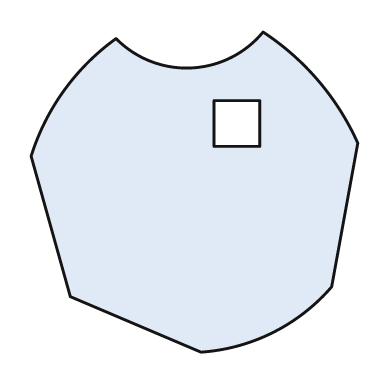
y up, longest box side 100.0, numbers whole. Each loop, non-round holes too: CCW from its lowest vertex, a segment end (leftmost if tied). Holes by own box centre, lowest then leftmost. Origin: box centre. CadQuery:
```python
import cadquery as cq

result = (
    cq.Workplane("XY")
    .moveTo(2.0, -49.0)
    .threePointArc((24.0, -43.0), (42.0, -29.0))
    .lineTo(50.0, 15.0)
    .threePointArc((38.0, 34.0), (21.0, 49.0))
    .threePointArc((-1.0, 38.0), (-24.0, 47.0))
    .threePointArc((-40.0, 31.0), (-50.0, 11.0))
    .lineTo(-38.0, -32.0)
    .close()
    .moveTo(6.0, 14.0)
    .lineTo(20.0, 14.0)
    .lineTo(20.0, 28.0)
    .lineTo(6.0, 28.0)
    .close()
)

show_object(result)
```